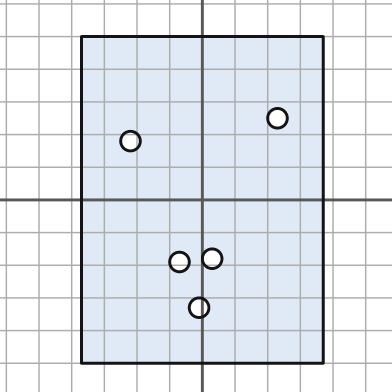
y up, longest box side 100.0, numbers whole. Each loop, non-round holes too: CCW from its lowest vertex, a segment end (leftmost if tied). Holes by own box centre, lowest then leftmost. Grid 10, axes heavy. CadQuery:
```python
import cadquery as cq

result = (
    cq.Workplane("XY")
    .moveTo(-37.0, -50.0)
    .lineTo(37.0, -50.0)
    .lineTo(37.0, 50.0)
    .lineTo(-37.0, 50.0)
    .close()
    .moveTo(-1.0, -33.0)
    .circle(3.0)
    .moveTo(-7.0, -19.0)
    .circle(3.0)
    .moveTo(3.0, -18.0)
    .circle(3.0)
    .moveTo(-22.0, 18.0)
    .circle(3.0)
    .moveTo(23.0, 25.0)
    .circle(3.0)
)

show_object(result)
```